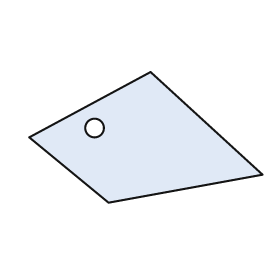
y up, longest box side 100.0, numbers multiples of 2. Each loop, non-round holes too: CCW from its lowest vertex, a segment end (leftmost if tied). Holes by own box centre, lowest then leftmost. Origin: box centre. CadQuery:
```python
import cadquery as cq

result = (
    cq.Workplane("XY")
    .moveTo(-16.0, -28.0)
    .lineTo(50.0, -16.0)
    .lineTo(2.0, 28.0)
    .lineTo(-50.0, 0.0)
    .close()
    .moveTo(-22.0, 4.0)
    .circle(4.0)
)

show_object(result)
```